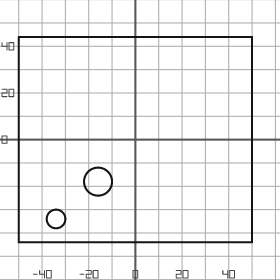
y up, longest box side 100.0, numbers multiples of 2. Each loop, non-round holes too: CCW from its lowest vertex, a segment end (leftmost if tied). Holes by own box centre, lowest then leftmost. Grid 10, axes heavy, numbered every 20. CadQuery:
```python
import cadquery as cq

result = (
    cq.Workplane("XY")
    .moveTo(-50.0, -44.0)
    .lineTo(50.0, -44.0)
    .lineTo(50.0, 44.0)
    .lineTo(-50.0, 44.0)
    .close()
    .moveTo(-34.0, -34.0)
    .circle(4.0)
    .moveTo(-16.0, -18.0)
    .circle(6.0)
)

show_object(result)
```